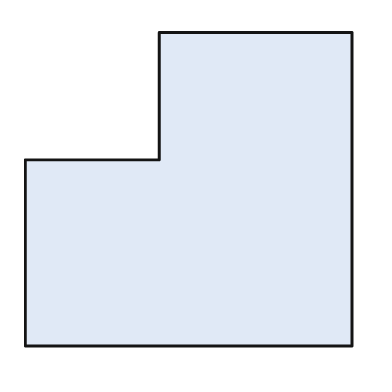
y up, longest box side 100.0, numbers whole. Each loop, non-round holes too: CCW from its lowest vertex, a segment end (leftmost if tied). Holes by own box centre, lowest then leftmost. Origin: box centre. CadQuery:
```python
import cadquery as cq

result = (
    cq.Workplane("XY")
    .moveTo(-50.0, -48.0)
    .lineTo(50.0, -48.0)
    .lineTo(50.0, 48.0)
    .lineTo(-9.0, 48.0)
    .lineTo(-9.0, 9.0)
    .lineTo(-50.0, 9.0)
    .close()
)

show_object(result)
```